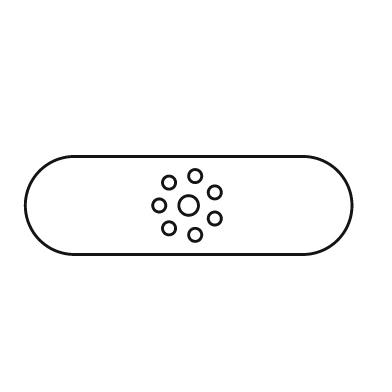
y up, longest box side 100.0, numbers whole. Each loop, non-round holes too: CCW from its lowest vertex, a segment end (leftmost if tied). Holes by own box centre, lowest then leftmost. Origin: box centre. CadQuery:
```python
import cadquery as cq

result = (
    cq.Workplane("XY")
    .moveTo(-35.0, -15.0)
    .lineTo(35.0, -15.0)
    .threePointArc((50.0, 0.0), (35.0, 15.0))
    .lineTo(-35.0, 15.0)
    .threePointArc((-50.0, 0.0), (-35.0, -15.0))
    .close()
    .moveTo(2.0, -9.0)
    .circle(2.0)
    .moveTo(-6.0, -7.0)
    .circle(2.0)
    .moveTo(8.0, -4.0)
    .circle(2.0)
    .moveTo(-9.0, 0.0)
    .circle(2.0)
    .moveTo(0.0, 0.0)
    .circle(3.0)
    .moveTo(8.0, 4.0)
    .circle(2.0)
    .moveTo(-6.0, 7.0)
    .circle(2.0)
    .moveTo(2.0, 9.0)
    .circle(2.0)
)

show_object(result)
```